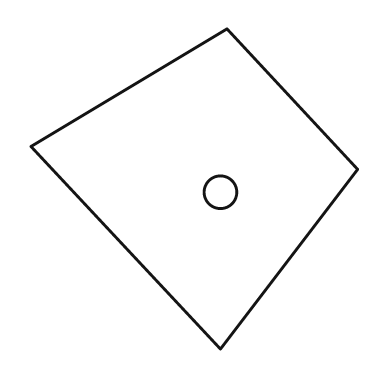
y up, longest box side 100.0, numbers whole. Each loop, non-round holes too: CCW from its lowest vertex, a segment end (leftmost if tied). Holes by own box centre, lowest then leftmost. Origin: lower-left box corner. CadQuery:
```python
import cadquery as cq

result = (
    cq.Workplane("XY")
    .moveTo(58.0, 0.0)
    .lineTo(100.0, 55.0)
    .lineTo(60.0, 98.0)
    .lineTo(0.0, 62.0)
    .close()
    .moveTo(58.0, 48.0)
    .circle(5.0)
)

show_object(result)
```